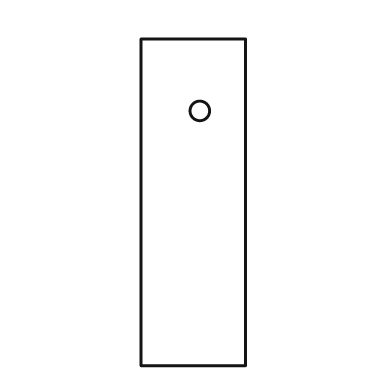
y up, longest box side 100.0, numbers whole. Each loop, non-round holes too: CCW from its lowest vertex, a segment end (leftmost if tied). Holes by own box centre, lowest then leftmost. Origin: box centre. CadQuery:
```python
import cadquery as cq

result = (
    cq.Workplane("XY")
    .moveTo(-16.0, -50.0)
    .lineTo(16.0, -50.0)
    .lineTo(16.0, 50.0)
    .lineTo(-16.0, 50.0)
    .close()
    .moveTo(2.0, 28.0)
    .circle(3.0)
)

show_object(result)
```